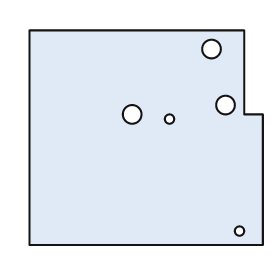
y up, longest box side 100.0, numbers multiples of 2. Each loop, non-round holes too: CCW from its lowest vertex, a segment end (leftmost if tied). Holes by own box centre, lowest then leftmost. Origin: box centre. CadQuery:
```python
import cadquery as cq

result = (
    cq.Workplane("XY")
    .moveTo(-50.0, -46.0)
    .lineTo(50.0, -46.0)
    .lineTo(50.0, 10.0)
    .lineTo(42.0, 10.0)
    .lineTo(42.0, 46.0)
    .lineTo(-50.0, 46.0)
    .close()
    .moveTo(40.0, -40.0)
    .circle(2.0)
    .moveTo(10.0, 8.0)
    .circle(2.0)
    .moveTo(-6.0, 10.0)
    .circle(4.0)
    .moveTo(34.0, 14.0)
    .circle(4.0)
    .moveTo(28.0, 38.0)
    .circle(4.0)
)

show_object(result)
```